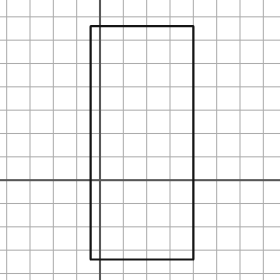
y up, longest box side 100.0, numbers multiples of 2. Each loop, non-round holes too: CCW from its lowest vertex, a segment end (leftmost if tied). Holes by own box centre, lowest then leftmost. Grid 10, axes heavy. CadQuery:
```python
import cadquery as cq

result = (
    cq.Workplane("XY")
    .moveTo(-4.0, -34.0)
    .lineTo(40.0, -34.0)
    .lineTo(40.0, 66.0)
    .lineTo(-4.0, 66.0)
    .close()
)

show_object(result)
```